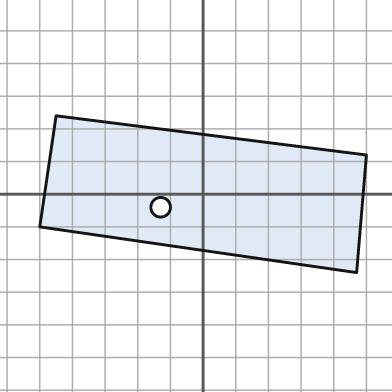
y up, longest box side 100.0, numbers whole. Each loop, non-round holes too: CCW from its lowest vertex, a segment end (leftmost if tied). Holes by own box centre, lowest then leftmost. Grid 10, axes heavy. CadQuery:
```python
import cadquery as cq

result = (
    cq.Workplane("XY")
    .moveTo(47.0, -24.0)
    .lineTo(50.0, 12.0)
    .lineTo(-45.0, 24.0)
    .lineTo(-50.0, -10.0)
    .close()
    .moveTo(-13.0, -4.0)
    .circle(3.0)
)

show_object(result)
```